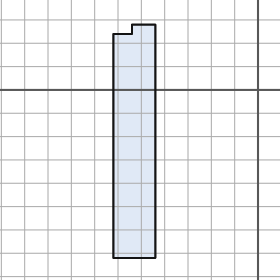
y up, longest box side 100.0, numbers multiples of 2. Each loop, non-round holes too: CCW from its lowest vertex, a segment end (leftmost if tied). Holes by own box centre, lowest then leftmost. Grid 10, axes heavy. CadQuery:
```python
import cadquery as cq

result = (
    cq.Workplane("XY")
    .moveTo(-62.0, -72.0)
    .lineTo(-44.0, -72.0)
    .lineTo(-44.0, 28.0)
    .lineTo(-54.0, 28.0)
    .lineTo(-54.0, 24.0)
    .lineTo(-62.0, 24.0)
    .close()
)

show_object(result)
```